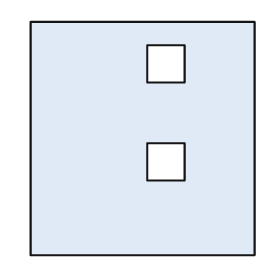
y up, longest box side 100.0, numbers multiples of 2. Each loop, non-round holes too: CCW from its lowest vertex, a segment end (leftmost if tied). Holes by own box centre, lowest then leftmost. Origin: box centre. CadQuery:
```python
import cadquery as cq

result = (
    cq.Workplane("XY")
    .moveTo(-48.0, -50.0)
    .lineTo(48.0, -50.0)
    .lineTo(48.0, 50.0)
    .lineTo(-48.0, 50.0)
    .close()
    .moveTo(2.0, -18.0)
    .lineTo(18.0, -18.0)
    .lineTo(18.0, -2.0)
    .lineTo(2.0, -2.0)
    .close()
    .moveTo(2.0, 24.0)
    .lineTo(18.0, 24.0)
    .lineTo(18.0, 40.0)
    .lineTo(2.0, 40.0)
    .close()
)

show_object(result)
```